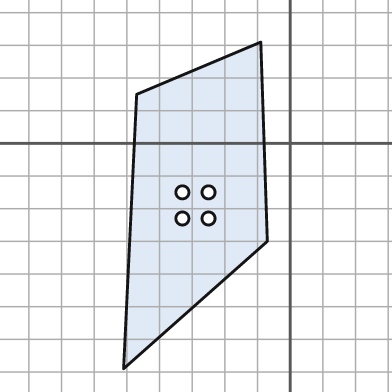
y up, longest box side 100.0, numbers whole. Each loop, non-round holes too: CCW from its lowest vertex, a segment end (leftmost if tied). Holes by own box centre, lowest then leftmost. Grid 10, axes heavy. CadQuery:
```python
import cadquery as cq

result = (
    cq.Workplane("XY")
    .moveTo(-51.0, -69.0)
    .lineTo(-7.0, -30.0)
    .lineTo(-9.0, 31.0)
    .lineTo(-47.0, 15.0)
    .close()
    .moveTo(-33.0, -23.0)
    .circle(2.0)
    .moveTo(-25.0, -23.0)
    .circle(2.0)
    .moveTo(-33.0, -15.0)
    .circle(2.0)
    .moveTo(-25.0, -15.0)
    .circle(2.0)
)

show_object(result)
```